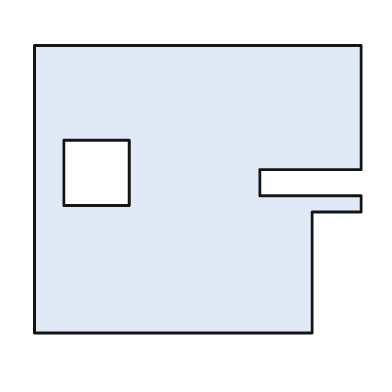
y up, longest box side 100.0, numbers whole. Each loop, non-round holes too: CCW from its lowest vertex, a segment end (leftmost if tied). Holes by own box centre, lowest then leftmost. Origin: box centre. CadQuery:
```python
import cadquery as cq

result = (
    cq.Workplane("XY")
    .moveTo(-50.0, -44.0)
    .lineTo(35.0, -44.0)
    .lineTo(35.0, -7.0)
    .lineTo(50.0, -7.0)
    .lineTo(50.0, -2.0)
    .lineTo(19.0, -2.0)
    .lineTo(19.0, 6.0)
    .lineTo(50.0, 6.0)
    .lineTo(50.0, 44.0)
    .lineTo(-50.0, 44.0)
    .close()
    .moveTo(-41.0, -5.0)
    .lineTo(-21.0, -5.0)
    .lineTo(-21.0, 15.0)
    .lineTo(-41.0, 15.0)
    .close()
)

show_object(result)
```